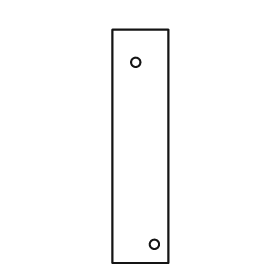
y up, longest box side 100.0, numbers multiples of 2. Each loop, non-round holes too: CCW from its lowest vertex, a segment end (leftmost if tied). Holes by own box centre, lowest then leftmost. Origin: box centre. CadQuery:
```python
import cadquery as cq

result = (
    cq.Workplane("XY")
    .moveTo(-12.0, -50.0)
    .lineTo(12.0, -50.0)
    .lineTo(12.0, 50.0)
    .lineTo(-12.0, 50.0)
    .close()
    .moveTo(6.0, -42.0)
    .circle(2.0)
    .moveTo(-2.0, 36.0)
    .circle(2.0)
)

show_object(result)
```